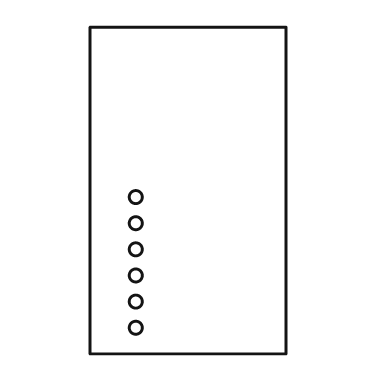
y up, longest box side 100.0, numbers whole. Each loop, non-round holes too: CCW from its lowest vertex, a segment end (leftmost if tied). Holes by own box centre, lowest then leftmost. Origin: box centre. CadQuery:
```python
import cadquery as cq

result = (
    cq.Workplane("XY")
    .moveTo(-30.0, -50.0)
    .lineTo(30.0, -50.0)
    .lineTo(30.0, 50.0)
    .lineTo(-30.0, 50.0)
    .close()
    .moveTo(-16.0, -42.0)
    .circle(2.0)
    .moveTo(-16.0, -34.0)
    .circle(2.0)
    .moveTo(-16.0, -26.0)
    .circle(2.0)
    .moveTo(-16.0, -18.0)
    .circle(2.0)
    .moveTo(-16.0, -10.0)
    .circle(2.0)
    .moveTo(-16.0, -2.0)
    .circle(2.0)
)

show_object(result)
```